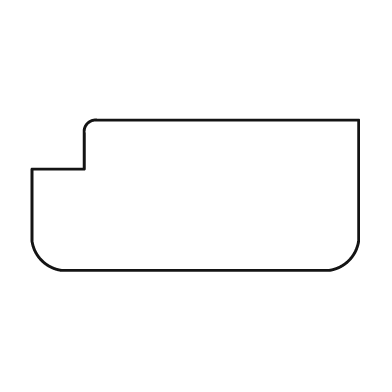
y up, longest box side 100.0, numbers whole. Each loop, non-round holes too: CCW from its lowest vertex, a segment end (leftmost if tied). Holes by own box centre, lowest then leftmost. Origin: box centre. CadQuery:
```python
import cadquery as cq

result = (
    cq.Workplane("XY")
    .moveTo(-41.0, -23.0)
    .lineTo(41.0, -23.0)
    .threePointArc((47.0, -20.0), (50.0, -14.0))
    .lineTo(50.0, 23.0)
    .lineTo(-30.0, 23.0)
    .threePointArc((-33.0, 22.0), (-34.0, 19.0))
    .lineTo(-34.0, 8.0)
    .lineTo(-50.0, 8.0)
    .lineTo(-50.0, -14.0)
    .threePointArc((-47.0, -20.0), (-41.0, -23.0))
    .close()
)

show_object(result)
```